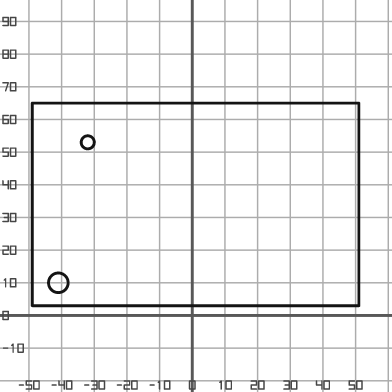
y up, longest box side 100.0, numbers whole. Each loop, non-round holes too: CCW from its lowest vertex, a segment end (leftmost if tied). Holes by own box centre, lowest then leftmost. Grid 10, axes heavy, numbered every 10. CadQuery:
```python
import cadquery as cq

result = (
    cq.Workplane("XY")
    .moveTo(-49.0, 3.0)
    .lineTo(51.0, 3.0)
    .lineTo(51.0, 65.0)
    .lineTo(-49.0, 65.0)
    .close()
    .moveTo(-41.0, 10.0)
    .circle(3.0)
    .moveTo(-32.0, 53.0)
    .circle(2.0)
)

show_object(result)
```